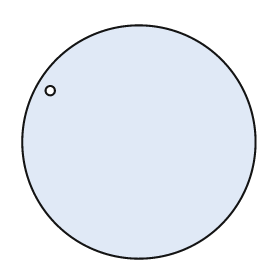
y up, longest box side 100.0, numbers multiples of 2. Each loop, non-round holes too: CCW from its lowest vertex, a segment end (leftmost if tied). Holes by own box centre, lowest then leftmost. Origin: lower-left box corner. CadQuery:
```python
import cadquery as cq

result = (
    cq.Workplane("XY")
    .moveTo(50.0, 50.0)
    .circle(50.0)
    .moveTo(12.0, 72.0)
    .circle(2.0)
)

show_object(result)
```